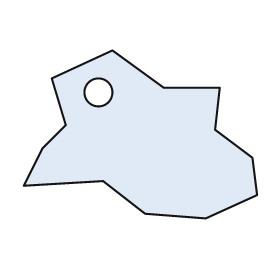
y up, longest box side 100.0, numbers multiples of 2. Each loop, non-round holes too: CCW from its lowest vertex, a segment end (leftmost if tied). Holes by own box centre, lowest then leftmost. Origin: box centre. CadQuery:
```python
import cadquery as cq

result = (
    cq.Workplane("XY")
    .moveTo(28.0, -36.0)
    .lineTo(50.0, -26.0)
    .lineTo(48.0, -10.0)
    .lineTo(32.0, 2.0)
    .lineTo(34.0, 20.0)
    .lineTo(10.0, 20.0)
    .lineTo(-12.0, 36.0)
    .lineTo(-38.0, 24.0)
    .lineTo(-32.0, 4.0)
    .lineTo(-42.0, -6.0)
    .lineTo(-50.0, -22.0)
    .lineTo(-16.0, -20.0)
    .lineTo(2.0, -34.0)
    .close()
    .moveTo(-18.0, 18.0)
    .circle(6.0)
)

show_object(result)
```